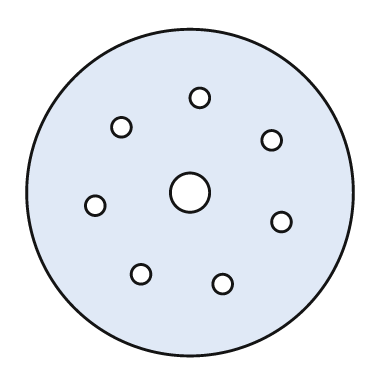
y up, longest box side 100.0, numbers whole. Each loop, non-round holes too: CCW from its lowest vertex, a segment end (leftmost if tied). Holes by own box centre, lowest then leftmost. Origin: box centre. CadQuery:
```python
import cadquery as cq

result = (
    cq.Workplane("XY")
    .moveTo(0.0, 0.0)
    .circle(50.0)
    .moveTo(10.0, -28.0)
    .circle(3.0)
    .moveTo(-15.0, -25.0)
    .circle(3.0)
    .moveTo(28.0, -9.0)
    .circle(3.0)
    .moveTo(-29.0, -4.0)
    .circle(3.0)
    .moveTo(0.0, 0.0)
    .circle(6.0)
    .moveTo(25.0, 16.0)
    .circle(3.0)
    .moveTo(-21.0, 20.0)
    .circle(3.0)
    .moveTo(3.0, 29.0)
    .circle(3.0)
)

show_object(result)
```